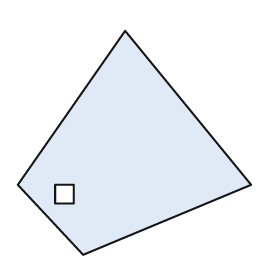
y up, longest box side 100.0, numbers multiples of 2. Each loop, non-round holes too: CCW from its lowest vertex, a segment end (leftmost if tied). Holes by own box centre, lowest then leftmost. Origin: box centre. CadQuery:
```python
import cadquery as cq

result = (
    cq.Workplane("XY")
    .moveTo(-22.0, -48.0)
    .lineTo(50.0, -18.0)
    .lineTo(-4.0, 48.0)
    .lineTo(-50.0, -18.0)
    .close()
    .moveTo(-34.0, -26.0)
    .lineTo(-26.0, -26.0)
    .lineTo(-26.0, -18.0)
    .lineTo(-34.0, -18.0)
    .close()
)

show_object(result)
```